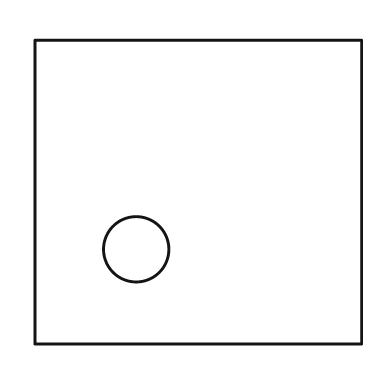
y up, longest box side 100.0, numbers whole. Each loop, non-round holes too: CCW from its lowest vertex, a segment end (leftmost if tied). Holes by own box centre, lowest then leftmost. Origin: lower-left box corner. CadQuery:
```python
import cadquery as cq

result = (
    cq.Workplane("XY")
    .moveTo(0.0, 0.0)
    .lineTo(100.0, 0.0)
    .lineTo(100.0, 93.0)
    .lineTo(0.0, 93.0)
    .close()
    .moveTo(31.0, 29.0)
    .circle(10.0)
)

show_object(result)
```